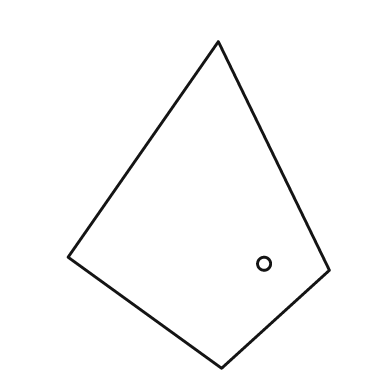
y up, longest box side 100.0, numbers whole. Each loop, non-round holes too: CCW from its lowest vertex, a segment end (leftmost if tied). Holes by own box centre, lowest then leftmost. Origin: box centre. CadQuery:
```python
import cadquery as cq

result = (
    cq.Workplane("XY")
    .moveTo(7.0, -50.0)
    .lineTo(40.0, -20.0)
    .lineTo(6.0, 50.0)
    .lineTo(-40.0, -16.0)
    .close()
    .moveTo(20.0, -18.0)
    .circle(2.0)
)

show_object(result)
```